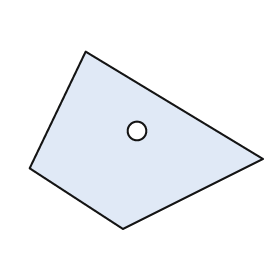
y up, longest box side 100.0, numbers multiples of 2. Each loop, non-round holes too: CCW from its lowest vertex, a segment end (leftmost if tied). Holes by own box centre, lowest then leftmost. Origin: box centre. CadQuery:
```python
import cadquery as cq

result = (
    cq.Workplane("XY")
    .moveTo(-10.0, -38.0)
    .lineTo(50.0, -8.0)
    .lineTo(-26.0, 38.0)
    .lineTo(-50.0, -12.0)
    .close()
    .moveTo(-4.0, 4.0)
    .circle(4.0)
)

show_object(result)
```